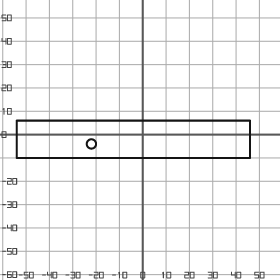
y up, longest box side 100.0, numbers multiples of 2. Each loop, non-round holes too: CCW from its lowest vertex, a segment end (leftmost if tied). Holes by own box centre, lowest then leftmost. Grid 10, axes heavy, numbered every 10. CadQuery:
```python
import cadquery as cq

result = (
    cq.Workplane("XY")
    .moveTo(-54.0, -10.0)
    .lineTo(46.0, -10.0)
    .lineTo(46.0, 6.0)
    .lineTo(-54.0, 6.0)
    .close()
    .moveTo(-22.0, -4.0)
    .circle(2.0)
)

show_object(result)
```